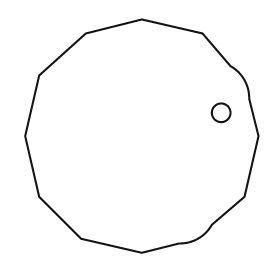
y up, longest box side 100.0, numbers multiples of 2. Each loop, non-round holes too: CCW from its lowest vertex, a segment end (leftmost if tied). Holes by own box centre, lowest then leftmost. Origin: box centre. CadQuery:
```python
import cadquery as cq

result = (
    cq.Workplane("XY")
    .moveTo(0.0, -50.0)
    .lineTo(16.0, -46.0)
    .threePointArc((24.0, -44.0), (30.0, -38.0))
    .lineTo(44.0, -26.0)
    .lineTo(50.0, 0.0)
    .lineTo(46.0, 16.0)
    .threePointArc((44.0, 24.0), (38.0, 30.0))
    .lineTo(26.0, 44.0)
    .lineTo(0.0, 50.0)
    .lineTo(-24.0, 44.0)
    .lineTo(-44.0, 26.0)
    .lineTo(-50.0, 0.0)
    .lineTo(-44.0, -26.0)
    .lineTo(-26.0, -44.0)
    .close()
    .moveTo(34.0, 10.0)
    .circle(4.0)
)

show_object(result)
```